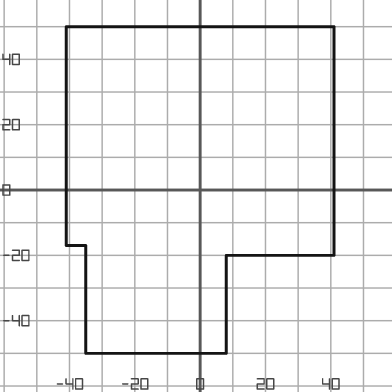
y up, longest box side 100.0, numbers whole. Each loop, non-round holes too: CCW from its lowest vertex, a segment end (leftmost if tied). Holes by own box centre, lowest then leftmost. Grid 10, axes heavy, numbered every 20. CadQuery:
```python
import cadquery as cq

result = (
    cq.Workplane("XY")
    .moveTo(-35.0, -50.0)
    .lineTo(8.0, -50.0)
    .lineTo(8.0, -20.0)
    .lineTo(41.0, -20.0)
    .lineTo(41.0, 50.0)
    .lineTo(-41.0, 50.0)
    .lineTo(-41.0, -17.0)
    .lineTo(-35.0, -17.0)
    .close()
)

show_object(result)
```